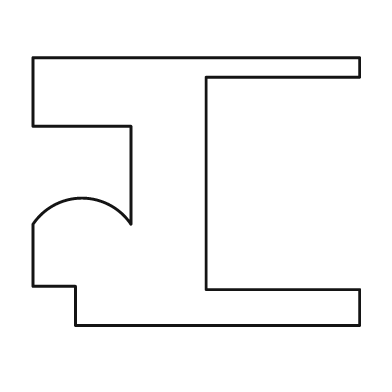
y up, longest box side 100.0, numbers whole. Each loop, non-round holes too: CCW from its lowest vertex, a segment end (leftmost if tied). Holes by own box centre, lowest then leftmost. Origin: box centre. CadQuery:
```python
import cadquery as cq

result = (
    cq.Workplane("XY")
    .moveTo(-37.0, -41.0)
    .lineTo(50.0, -41.0)
    .lineTo(50.0, -30.0)
    .lineTo(3.0, -30.0)
    .lineTo(3.0, 35.0)
    .lineTo(50.0, 35.0)
    .lineTo(50.0, 41.0)
    .lineTo(-50.0, 41.0)
    .lineTo(-50.0, 20.0)
    .lineTo(-20.0, 20.0)
    .lineTo(-20.0, -10.0)
    .threePointArc((-35.0, -2.0), (-50.0, -10.0))
    .lineTo(-50.0, -29.0)
    .lineTo(-37.0, -29.0)
    .close()
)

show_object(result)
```